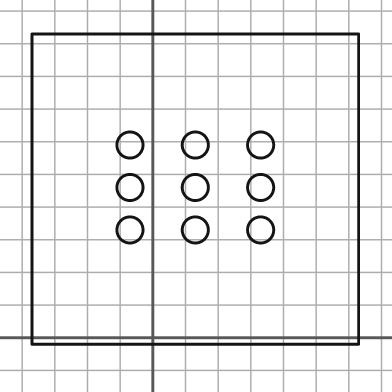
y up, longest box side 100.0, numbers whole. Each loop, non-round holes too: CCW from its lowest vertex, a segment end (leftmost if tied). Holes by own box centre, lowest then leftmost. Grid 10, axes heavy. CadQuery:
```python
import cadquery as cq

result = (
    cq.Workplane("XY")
    .moveTo(-37.0, -2.0)
    .lineTo(63.0, -2.0)
    .lineTo(63.0, 93.0)
    .lineTo(-37.0, 93.0)
    .close()
    .moveTo(-7.0, 33.0)
    .circle(4.0)
    .moveTo(13.0, 33.0)
    .circle(4.0)
    .moveTo(33.0, 33.0)
    .circle(4.0)
    .moveTo(-7.0, 46.0)
    .circle(4.0)
    .moveTo(13.0, 46.0)
    .circle(4.0)
    .moveTo(33.0, 46.0)
    .circle(4.0)
    .moveTo(-7.0, 59.0)
    .circle(4.0)
    .moveTo(13.0, 59.0)
    .circle(4.0)
    .moveTo(33.0, 59.0)
    .circle(4.0)
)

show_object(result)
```